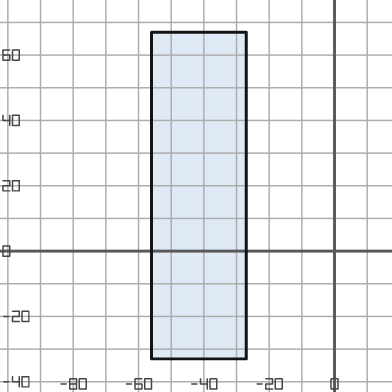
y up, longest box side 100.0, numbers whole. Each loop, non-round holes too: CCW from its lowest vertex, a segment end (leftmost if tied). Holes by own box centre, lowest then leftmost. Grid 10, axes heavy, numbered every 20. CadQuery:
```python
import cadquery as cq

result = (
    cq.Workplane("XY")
    .moveTo(-56.0, -33.0)
    .lineTo(-27.0, -33.0)
    .lineTo(-27.0, 67.0)
    .lineTo(-56.0, 67.0)
    .close()
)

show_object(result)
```